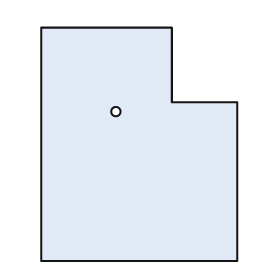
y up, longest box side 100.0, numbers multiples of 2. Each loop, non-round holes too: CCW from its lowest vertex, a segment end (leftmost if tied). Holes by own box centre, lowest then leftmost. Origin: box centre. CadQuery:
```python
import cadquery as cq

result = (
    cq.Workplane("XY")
    .moveTo(-42.0, -50.0)
    .lineTo(42.0, -50.0)
    .lineTo(42.0, 18.0)
    .lineTo(14.0, 18.0)
    .lineTo(14.0, 50.0)
    .lineTo(-42.0, 50.0)
    .close()
    .moveTo(-10.0, 14.0)
    .circle(2.0)
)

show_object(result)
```